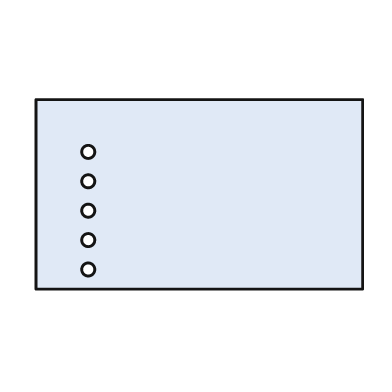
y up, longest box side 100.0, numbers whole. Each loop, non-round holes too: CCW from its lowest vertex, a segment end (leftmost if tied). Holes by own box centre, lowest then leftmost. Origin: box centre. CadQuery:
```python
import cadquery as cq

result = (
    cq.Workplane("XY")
    .moveTo(-50.0, -29.0)
    .lineTo(50.0, -29.0)
    .lineTo(50.0, 29.0)
    .lineTo(-50.0, 29.0)
    .close()
    .moveTo(-34.0, -23.0)
    .circle(2.0)
    .moveTo(-34.0, -14.0)
    .circle(2.0)
    .moveTo(-34.0, -5.0)
    .circle(2.0)
    .moveTo(-34.0, 4.0)
    .circle(2.0)
    .moveTo(-34.0, 13.0)
    .circle(2.0)
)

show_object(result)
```